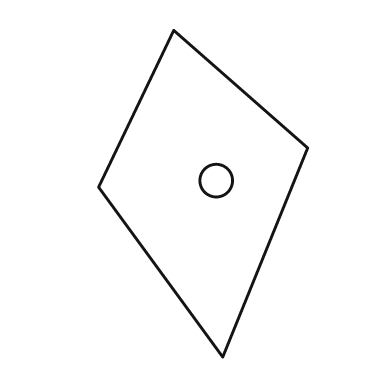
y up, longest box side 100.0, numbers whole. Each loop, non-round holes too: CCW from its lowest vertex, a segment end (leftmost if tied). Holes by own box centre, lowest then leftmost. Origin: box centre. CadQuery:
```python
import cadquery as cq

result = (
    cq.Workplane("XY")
    .moveTo(6.0, -50.0)
    .lineTo(32.0, 14.0)
    .lineTo(-9.0, 50.0)
    .lineTo(-32.0, 2.0)
    .close()
    .moveTo(4.0, 4.0)
    .circle(5.0)
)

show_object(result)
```